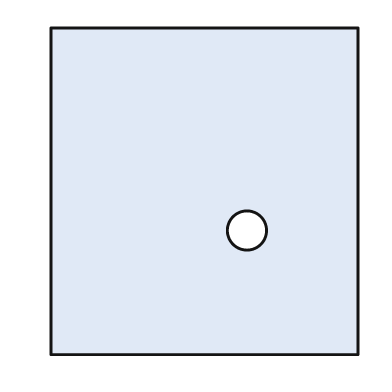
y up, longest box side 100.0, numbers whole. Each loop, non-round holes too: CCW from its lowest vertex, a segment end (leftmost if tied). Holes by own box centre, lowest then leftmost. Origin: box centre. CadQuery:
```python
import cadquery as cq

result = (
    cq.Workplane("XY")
    .moveTo(-47.0, -50.0)
    .lineTo(47.0, -50.0)
    .lineTo(47.0, 50.0)
    .lineTo(-47.0, 50.0)
    .close()
    .moveTo(13.0, -12.0)
    .circle(6.0)
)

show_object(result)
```